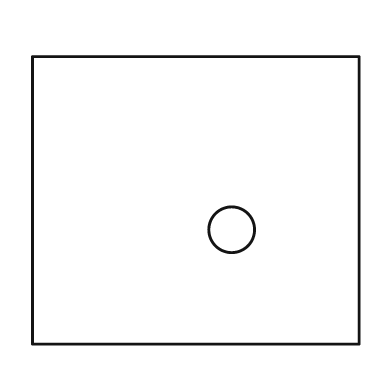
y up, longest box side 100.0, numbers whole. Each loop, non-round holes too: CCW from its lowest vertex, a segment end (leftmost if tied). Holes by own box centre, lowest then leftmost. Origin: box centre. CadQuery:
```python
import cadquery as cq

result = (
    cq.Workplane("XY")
    .moveTo(-50.0, -44.0)
    .lineTo(50.0, -44.0)
    .lineTo(50.0, 44.0)
    .lineTo(-50.0, 44.0)
    .close()
    .moveTo(11.0, -9.0)
    .circle(7.0)
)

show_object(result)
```